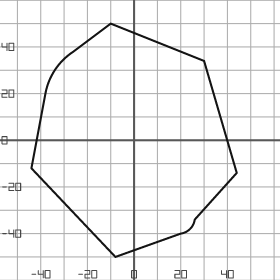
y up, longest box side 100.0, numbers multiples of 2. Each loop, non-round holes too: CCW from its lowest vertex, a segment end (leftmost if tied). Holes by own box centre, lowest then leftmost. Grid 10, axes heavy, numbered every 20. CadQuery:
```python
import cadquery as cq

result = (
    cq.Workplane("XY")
    .moveTo(-8.0, -50.0)
    .lineTo(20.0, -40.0)
    .threePointArc((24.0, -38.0), (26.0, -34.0))
    .lineTo(44.0, -14.0)
    .lineTo(30.0, 34.0)
    .lineTo(-10.0, 50.0)
    .lineTo(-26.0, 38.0)
    .threePointArc((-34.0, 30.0), (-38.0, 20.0))
    .lineTo(-44.0, -12.0)
    .close()
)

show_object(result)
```